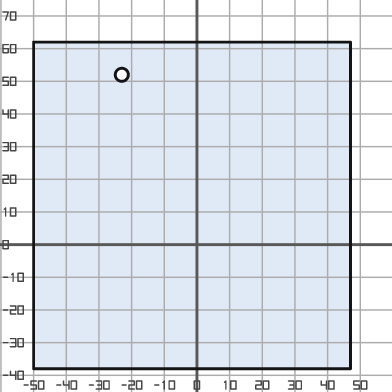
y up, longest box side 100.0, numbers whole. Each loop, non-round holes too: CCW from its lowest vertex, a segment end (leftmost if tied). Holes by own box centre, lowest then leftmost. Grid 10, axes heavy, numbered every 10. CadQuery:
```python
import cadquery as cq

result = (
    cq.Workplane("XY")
    .moveTo(-50.0, -38.0)
    .lineTo(47.0, -38.0)
    .lineTo(47.0, 62.0)
    .lineTo(-50.0, 62.0)
    .close()
    .moveTo(-23.0, 52.0)
    .circle(2.0)
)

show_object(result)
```